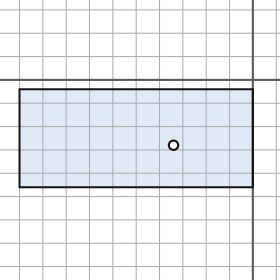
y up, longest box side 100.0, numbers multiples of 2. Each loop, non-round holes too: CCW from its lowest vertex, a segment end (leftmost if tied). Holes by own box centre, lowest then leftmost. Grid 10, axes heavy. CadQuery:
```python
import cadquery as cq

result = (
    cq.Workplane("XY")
    .moveTo(-100.0, -46.0)
    .lineTo(0.0, -46.0)
    .lineTo(0.0, -4.0)
    .lineTo(-100.0, -4.0)
    .close()
    .moveTo(-34.0, -28.0)
    .circle(2.0)
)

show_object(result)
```